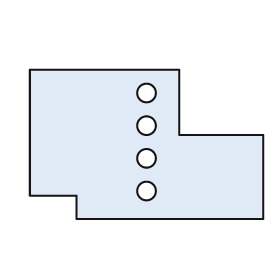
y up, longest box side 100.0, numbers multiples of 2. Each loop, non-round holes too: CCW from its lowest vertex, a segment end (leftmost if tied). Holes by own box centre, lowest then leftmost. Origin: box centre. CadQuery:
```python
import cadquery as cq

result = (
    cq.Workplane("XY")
    .moveTo(-30.0, -32.0)
    .lineTo(50.0, -32.0)
    .lineTo(50.0, 4.0)
    .lineTo(14.0, 4.0)
    .lineTo(14.0, 32.0)
    .lineTo(-50.0, 32.0)
    .lineTo(-50.0, -22.0)
    .lineTo(-30.0, -22.0)
    .close()
    .moveTo(0.0, -20.0)
    .circle(4.0)
    .moveTo(0.0, -6.0)
    .circle(4.0)
    .moveTo(0.0, 8.0)
    .circle(4.0)
    .moveTo(0.0, 22.0)
    .circle(4.0)
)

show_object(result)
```